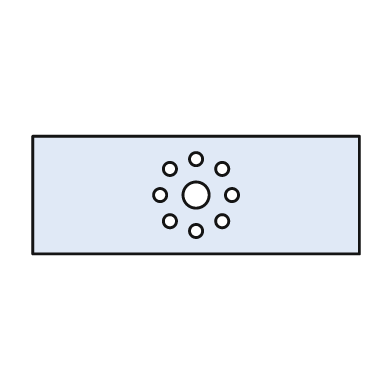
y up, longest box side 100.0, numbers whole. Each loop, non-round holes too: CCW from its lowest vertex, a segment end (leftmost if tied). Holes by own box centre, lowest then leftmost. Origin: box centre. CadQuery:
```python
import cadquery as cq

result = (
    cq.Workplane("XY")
    .moveTo(-50.0, -18.0)
    .lineTo(50.0, -18.0)
    .lineTo(50.0, 18.0)
    .lineTo(-50.0, 18.0)
    .close()
    .moveTo(0.0, -11.0)
    .circle(2.0)
    .moveTo(-8.0, -8.0)
    .circle(2.0)
    .moveTo(8.0, -8.0)
    .circle(2.0)
    .moveTo(-11.0, 0.0)
    .circle(2.0)
    .moveTo(0.0, 0.0)
    .circle(4.0)
    .moveTo(11.0, 0.0)
    .circle(2.0)
    .moveTo(-8.0, 8.0)
    .circle(2.0)
    .moveTo(8.0, 8.0)
    .circle(2.0)
    .moveTo(0.0, 11.0)
    .circle(2.0)
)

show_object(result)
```